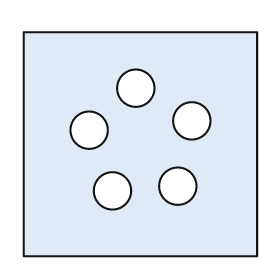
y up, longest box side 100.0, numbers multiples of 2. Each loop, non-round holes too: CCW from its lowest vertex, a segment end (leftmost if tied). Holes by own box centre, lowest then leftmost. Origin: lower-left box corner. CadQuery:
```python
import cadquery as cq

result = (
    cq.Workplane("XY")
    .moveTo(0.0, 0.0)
    .lineTo(100.0, 0.0)
    .lineTo(100.0, 96.0)
    .lineTo(0.0, 96.0)
    .close()
    .moveTo(38.0, 28.0)
    .circle(8.0)
    .moveTo(66.0, 30.0)
    .circle(8.0)
    .moveTo(28.0, 54.0)
    .circle(8.0)
    .moveTo(72.0, 58.0)
    .circle(8.0)
    .moveTo(48.0, 72.0)
    .circle(8.0)
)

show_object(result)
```